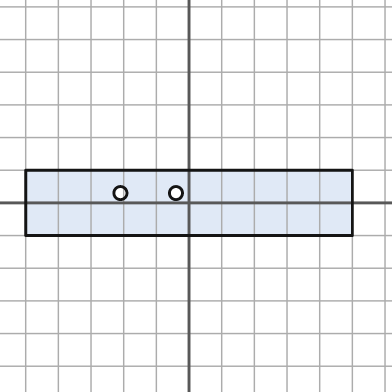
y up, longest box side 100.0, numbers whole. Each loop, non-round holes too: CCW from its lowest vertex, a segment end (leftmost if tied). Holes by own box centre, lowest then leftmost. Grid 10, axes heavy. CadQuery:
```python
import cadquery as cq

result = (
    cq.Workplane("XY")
    .moveTo(-50.0, -10.0)
    .lineTo(50.0, -10.0)
    .lineTo(50.0, 10.0)
    .lineTo(-50.0, 10.0)
    .close()
    .moveTo(-21.0, 3.0)
    .circle(2.0)
    .moveTo(-4.0, 3.0)
    .circle(2.0)
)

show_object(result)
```